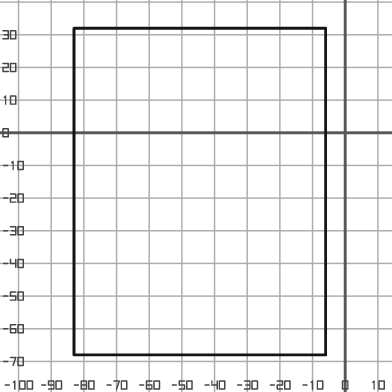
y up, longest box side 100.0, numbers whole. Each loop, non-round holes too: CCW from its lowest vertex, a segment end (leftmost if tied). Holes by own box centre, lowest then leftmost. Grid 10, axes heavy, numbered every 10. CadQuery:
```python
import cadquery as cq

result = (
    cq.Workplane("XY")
    .moveTo(-83.0, -68.0)
    .lineTo(-6.0, -68.0)
    .lineTo(-6.0, 32.0)
    .lineTo(-83.0, 32.0)
    .close()
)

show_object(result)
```